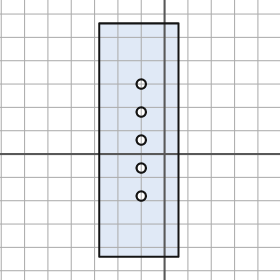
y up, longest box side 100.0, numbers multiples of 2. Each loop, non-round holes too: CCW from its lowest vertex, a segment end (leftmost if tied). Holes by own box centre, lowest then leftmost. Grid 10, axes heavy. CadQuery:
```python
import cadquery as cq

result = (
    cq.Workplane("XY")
    .moveTo(-28.0, -44.0)
    .lineTo(6.0, -44.0)
    .lineTo(6.0, 56.0)
    .lineTo(-28.0, 56.0)
    .close()
    .moveTo(-10.0, -18.0)
    .circle(2.0)
    .moveTo(-10.0, -6.0)
    .circle(2.0)
    .moveTo(-10.0, 6.0)
    .circle(2.0)
    .moveTo(-10.0, 18.0)
    .circle(2.0)
    .moveTo(-10.0, 30.0)
    .circle(2.0)
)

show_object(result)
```